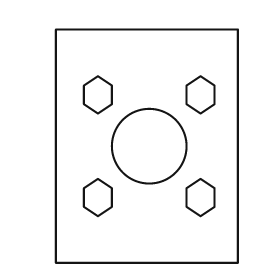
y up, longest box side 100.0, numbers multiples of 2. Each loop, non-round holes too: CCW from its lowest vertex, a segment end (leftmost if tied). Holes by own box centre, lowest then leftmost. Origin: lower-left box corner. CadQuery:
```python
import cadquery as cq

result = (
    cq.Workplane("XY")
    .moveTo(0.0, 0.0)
    .lineTo(78.0, 0.0)
    .lineTo(78.0, 100.0)
    .lineTo(0.0, 100.0)
    .close()
    .moveTo(18.0, 20.0)
    .lineTo(24.0, 24.0)
    .lineTo(24.0, 32.0)
    .lineTo(18.0, 36.0)
    .lineTo(12.0, 32.0)
    .lineTo(12.0, 24.0)
    .close()
    .moveTo(62.0, 20.0)
    .lineTo(68.0, 24.0)
    .lineTo(68.0, 32.0)
    .lineTo(62.0, 36.0)
    .lineTo(56.0, 32.0)
    .lineTo(56.0, 24.0)
    .close()
    .moveTo(40.0, 50.0)
    .circle(16.0)
    .moveTo(18.0, 64.0)
    .lineTo(24.0, 68.0)
    .lineTo(24.0, 76.0)
    .lineTo(18.0, 80.0)
    .lineTo(12.0, 76.0)
    .lineTo(12.0, 68.0)
    .close()
    .moveTo(62.0, 64.0)
    .lineTo(68.0, 68.0)
    .lineTo(68.0, 76.0)
    .lineTo(62.0, 80.0)
    .lineTo(56.0, 76.0)
    .lineTo(56.0, 68.0)
    .close()
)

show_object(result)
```